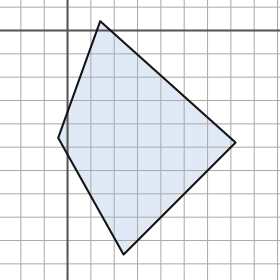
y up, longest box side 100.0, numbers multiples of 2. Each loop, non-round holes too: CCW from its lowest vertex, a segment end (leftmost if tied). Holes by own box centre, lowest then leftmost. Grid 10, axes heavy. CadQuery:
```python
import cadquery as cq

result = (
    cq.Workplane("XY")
    .moveTo(24.0, -96.0)
    .lineTo(72.0, -48.0)
    .lineTo(14.0, 4.0)
    .lineTo(-4.0, -46.0)
    .close()
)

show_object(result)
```